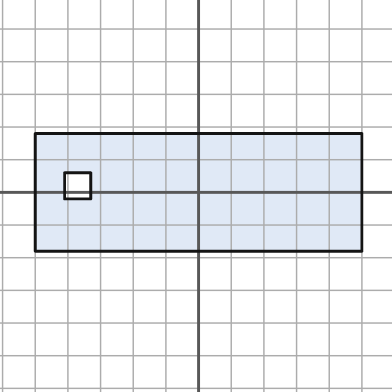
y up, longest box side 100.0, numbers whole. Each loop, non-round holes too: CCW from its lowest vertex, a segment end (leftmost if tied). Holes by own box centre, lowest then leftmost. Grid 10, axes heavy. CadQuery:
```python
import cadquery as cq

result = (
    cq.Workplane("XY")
    .moveTo(-50.0, -18.0)
    .lineTo(50.0, -18.0)
    .lineTo(50.0, 18.0)
    .lineTo(-50.0, 18.0)
    .close()
    .moveTo(-41.0, -2.0)
    .lineTo(-33.0, -2.0)
    .lineTo(-33.0, 6.0)
    .lineTo(-41.0, 6.0)
    .close()
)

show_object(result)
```